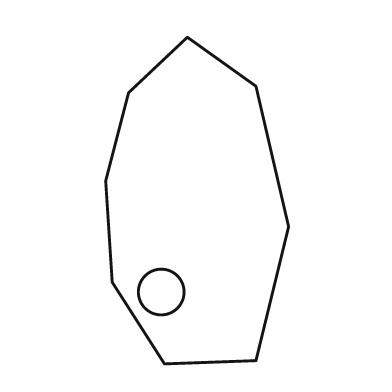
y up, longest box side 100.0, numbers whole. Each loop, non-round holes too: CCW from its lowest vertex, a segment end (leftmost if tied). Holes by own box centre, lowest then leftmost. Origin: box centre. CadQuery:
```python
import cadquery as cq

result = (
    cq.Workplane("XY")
    .moveTo(-10.0, -50.0)
    .lineTo(18.0, -49.0)
    .lineTo(28.0, -8.0)
    .lineTo(18.0, 35.0)
    .lineTo(-3.0, 50.0)
    .lineTo(-21.0, 33.0)
    .lineTo(-28.0, 6.0)
    .lineTo(-26.0, -25.0)
    .close()
    .moveTo(-11.0, -28.0)
    .circle(7.0)
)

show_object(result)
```